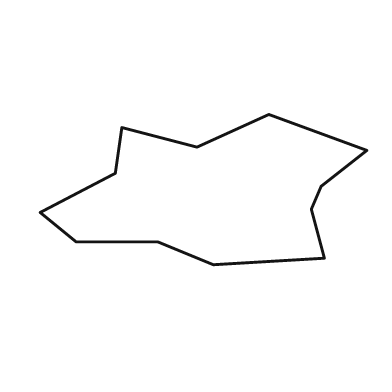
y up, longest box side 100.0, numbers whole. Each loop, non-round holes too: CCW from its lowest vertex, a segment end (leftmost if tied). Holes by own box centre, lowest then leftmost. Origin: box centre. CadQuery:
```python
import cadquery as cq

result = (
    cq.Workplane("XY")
    .moveTo(3.0, -23.0)
    .lineTo(37.0, -21.0)
    .lineTo(33.0, -6.0)
    .lineTo(36.0, 1.0)
    .lineTo(50.0, 12.0)
    .lineTo(20.0, 23.0)
    .lineTo(-2.0, 13.0)
    .lineTo(-25.0, 19.0)
    .lineTo(-27.0, 5.0)
    .lineTo(-50.0, -7.0)
    .lineTo(-39.0, -16.0)
    .lineTo(-14.0, -16.0)
    .close()
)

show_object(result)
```